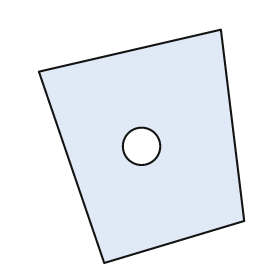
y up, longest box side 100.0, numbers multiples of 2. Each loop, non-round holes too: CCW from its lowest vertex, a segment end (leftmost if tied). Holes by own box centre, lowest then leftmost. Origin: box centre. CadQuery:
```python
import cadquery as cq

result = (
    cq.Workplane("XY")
    .moveTo(-16.0, -50.0)
    .lineTo(44.0, -32.0)
    .lineTo(34.0, 50.0)
    .lineTo(-44.0, 32.0)
    .close()
    .moveTo(0.0, 0.0)
    .circle(8.0)
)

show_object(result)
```